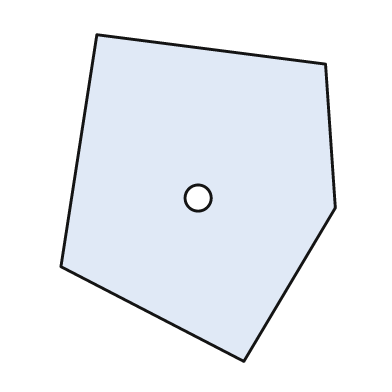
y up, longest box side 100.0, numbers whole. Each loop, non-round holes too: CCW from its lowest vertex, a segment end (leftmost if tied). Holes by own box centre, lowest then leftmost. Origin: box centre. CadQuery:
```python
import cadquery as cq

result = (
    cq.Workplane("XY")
    .moveTo(14.0, -50.0)
    .lineTo(42.0, -3.0)
    .lineTo(39.0, 41.0)
    .lineTo(-31.0, 50.0)
    .lineTo(-42.0, -21.0)
    .close()
    .moveTo(0.0, 0.0)
    .circle(4.0)
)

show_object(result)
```